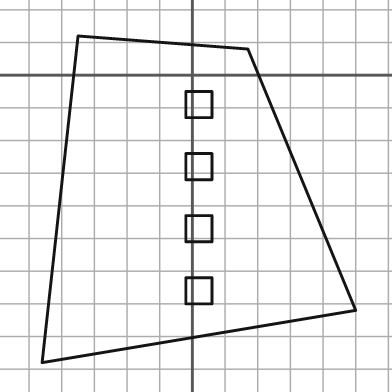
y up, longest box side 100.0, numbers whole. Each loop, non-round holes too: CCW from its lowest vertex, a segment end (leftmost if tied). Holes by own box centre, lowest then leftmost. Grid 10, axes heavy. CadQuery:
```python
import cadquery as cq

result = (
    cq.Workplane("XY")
    .moveTo(-46.0, -88.0)
    .lineTo(50.0, -72.0)
    .lineTo(17.0, 8.0)
    .lineTo(-35.0, 12.0)
    .close()
    .moveTo(-2.0, -70.0)
    .lineTo(6.0, -70.0)
    .lineTo(6.0, -62.0)
    .lineTo(-2.0, -62.0)
    .close()
    .moveTo(-2.0, -51.0)
    .lineTo(6.0, -51.0)
    .lineTo(6.0, -43.0)
    .lineTo(-2.0, -43.0)
    .close()
    .moveTo(-2.0, -32.0)
    .lineTo(6.0, -32.0)
    .lineTo(6.0, -24.0)
    .lineTo(-2.0, -24.0)
    .close()
    .moveTo(-2.0, -13.0)
    .lineTo(6.0, -13.0)
    .lineTo(6.0, -5.0)
    .lineTo(-2.0, -5.0)
    .close()
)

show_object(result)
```